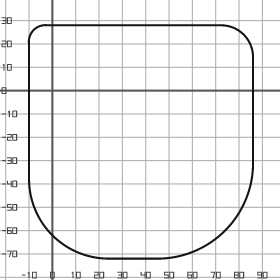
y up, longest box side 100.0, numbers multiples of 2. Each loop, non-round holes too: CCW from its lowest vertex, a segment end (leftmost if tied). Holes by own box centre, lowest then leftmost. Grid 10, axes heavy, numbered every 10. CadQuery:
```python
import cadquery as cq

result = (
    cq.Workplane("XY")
    .moveTo(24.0, -72.0)
    .lineTo(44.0, -72.0)
    .threePointArc((74.0, -60.0), (86.0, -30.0))
    .lineTo(86.0, 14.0)
    .threePointArc((82.0, 24.0), (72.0, 28.0))
    .lineTo(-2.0, 28.0)
    .threePointArc((-8.0, 26.0), (-10.0, 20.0))
    .lineTo(-10.0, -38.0)
    .threePointArc((0.0, -62.0), (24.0, -72.0))
    .close()
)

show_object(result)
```